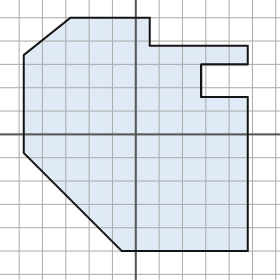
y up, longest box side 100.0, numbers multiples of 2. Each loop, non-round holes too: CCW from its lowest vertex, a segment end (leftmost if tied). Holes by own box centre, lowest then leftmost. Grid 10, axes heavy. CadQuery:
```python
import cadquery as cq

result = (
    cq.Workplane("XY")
    .moveTo(-6.0, -50.0)
    .lineTo(48.0, -50.0)
    .lineTo(48.0, 16.0)
    .lineTo(28.0, 16.0)
    .lineTo(28.0, 30.0)
    .lineTo(48.0, 30.0)
    .lineTo(48.0, 38.0)
    .lineTo(6.0, 38.0)
    .lineTo(6.0, 50.0)
    .lineTo(-28.0, 50.0)
    .lineTo(-48.0, 34.0)
    .lineTo(-48.0, -8.0)
    .close()
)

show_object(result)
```